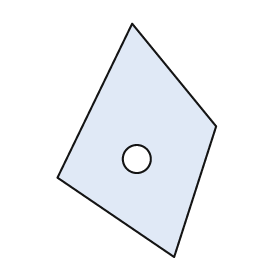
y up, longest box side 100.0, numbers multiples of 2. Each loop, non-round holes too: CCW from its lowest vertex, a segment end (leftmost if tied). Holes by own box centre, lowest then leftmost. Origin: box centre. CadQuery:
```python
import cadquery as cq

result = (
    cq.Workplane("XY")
    .moveTo(16.0, -50.0)
    .lineTo(34.0, 6.0)
    .lineTo(-2.0, 50.0)
    .lineTo(-34.0, -16.0)
    .close()
    .moveTo(0.0, -8.0)
    .circle(6.0)
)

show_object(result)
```